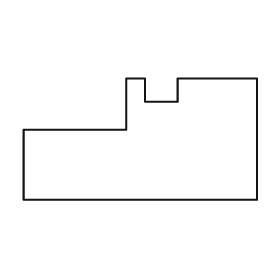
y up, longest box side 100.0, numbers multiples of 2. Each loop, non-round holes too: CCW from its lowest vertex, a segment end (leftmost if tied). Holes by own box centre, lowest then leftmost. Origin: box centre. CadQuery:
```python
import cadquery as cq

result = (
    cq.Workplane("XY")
    .moveTo(-50.0, -26.0)
    .lineTo(50.0, -26.0)
    .lineTo(50.0, 26.0)
    .lineTo(16.0, 26.0)
    .lineTo(16.0, 16.0)
    .lineTo(2.0, 16.0)
    .lineTo(2.0, 26.0)
    .lineTo(-6.0, 26.0)
    .lineTo(-6.0, 4.0)
    .lineTo(-50.0, 4.0)
    .close()
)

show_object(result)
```